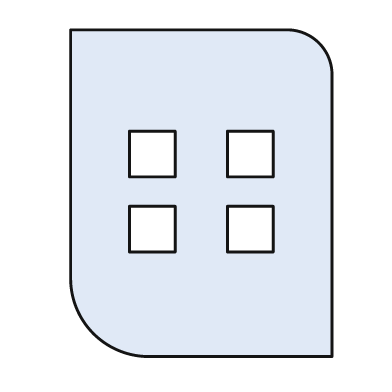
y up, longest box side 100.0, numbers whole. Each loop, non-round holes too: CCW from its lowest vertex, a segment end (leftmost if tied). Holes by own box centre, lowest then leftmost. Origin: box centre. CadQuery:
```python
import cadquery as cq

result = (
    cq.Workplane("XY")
    .moveTo(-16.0, -50.0)
    .lineTo(40.0, -50.0)
    .lineTo(40.0, 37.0)
    .threePointArc((36.0, 46.0), (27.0, 50.0))
    .lineTo(-40.0, 50.0)
    .lineTo(-40.0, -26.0)
    .threePointArc((-33.0, -43.0), (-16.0, -50.0))
    .close()
    .moveTo(-22.0, -18.0)
    .lineTo(-8.0, -18.0)
    .lineTo(-8.0, -4.0)
    .lineTo(-22.0, -4.0)
    .close()
    .moveTo(8.0, -18.0)
    .lineTo(22.0, -18.0)
    .lineTo(22.0, -4.0)
    .lineTo(8.0, -4.0)
    .close()
    .moveTo(-22.0, 5.0)
    .lineTo(-8.0, 5.0)
    .lineTo(-8.0, 19.0)
    .lineTo(-22.0, 19.0)
    .close()
    .moveTo(8.0, 5.0)
    .lineTo(22.0, 5.0)
    .lineTo(22.0, 19.0)
    .lineTo(8.0, 19.0)
    .close()
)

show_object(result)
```